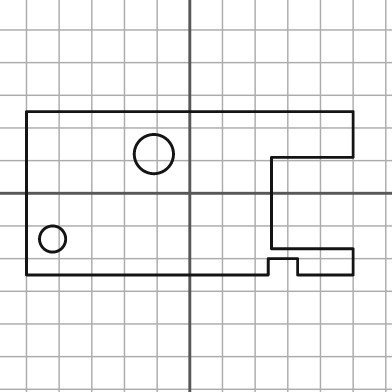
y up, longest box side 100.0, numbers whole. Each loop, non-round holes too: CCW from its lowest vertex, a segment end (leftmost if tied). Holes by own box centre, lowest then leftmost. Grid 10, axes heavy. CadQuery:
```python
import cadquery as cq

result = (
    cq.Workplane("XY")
    .moveTo(-50.0, -25.0)
    .lineTo(24.0, -25.0)
    .lineTo(24.0, -20.0)
    .lineTo(33.0, -20.0)
    .lineTo(33.0, -25.0)
    .lineTo(50.0, -25.0)
    .lineTo(50.0, -17.0)
    .lineTo(25.0, -17.0)
    .lineTo(25.0, 11.0)
    .lineTo(50.0, 11.0)
    .lineTo(50.0, 25.0)
    .lineTo(-50.0, 25.0)
    .close()
    .moveTo(-42.0, -14.0)
    .circle(4.0)
    .moveTo(-11.0, 12.0)
    .circle(6.0)
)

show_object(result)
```